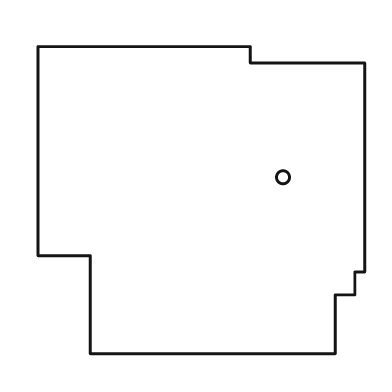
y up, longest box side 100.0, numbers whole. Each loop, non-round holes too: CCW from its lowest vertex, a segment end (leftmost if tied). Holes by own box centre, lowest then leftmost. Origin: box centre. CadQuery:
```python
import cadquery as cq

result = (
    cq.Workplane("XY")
    .moveTo(-34.0, -47.0)
    .lineTo(41.0, -47.0)
    .lineTo(41.0, -29.0)
    .lineTo(47.0, -29.0)
    .lineTo(47.0, -22.0)
    .lineTo(50.0, -22.0)
    .lineTo(50.0, 42.0)
    .lineTo(15.0, 42.0)
    .lineTo(15.0, 47.0)
    .lineTo(-50.0, 47.0)
    .lineTo(-50.0, -17.0)
    .lineTo(-34.0, -17.0)
    .close()
    .moveTo(25.0, 7.0)
    .circle(2.0)
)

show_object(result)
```